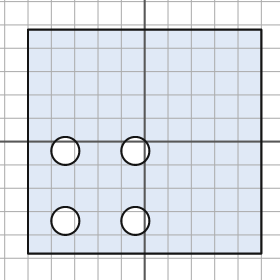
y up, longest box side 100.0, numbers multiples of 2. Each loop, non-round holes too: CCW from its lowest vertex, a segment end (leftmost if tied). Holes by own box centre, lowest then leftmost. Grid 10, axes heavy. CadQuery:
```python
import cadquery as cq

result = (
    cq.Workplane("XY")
    .moveTo(-50.0, -48.0)
    .lineTo(50.0, -48.0)
    .lineTo(50.0, 48.0)
    .lineTo(-50.0, 48.0)
    .close()
    .moveTo(-34.0, -34.0)
    .circle(6.0)
    .moveTo(-4.0, -34.0)
    .circle(6.0)
    .moveTo(-34.0, -4.0)
    .circle(6.0)
    .moveTo(-4.0, -4.0)
    .circle(6.0)
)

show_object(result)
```